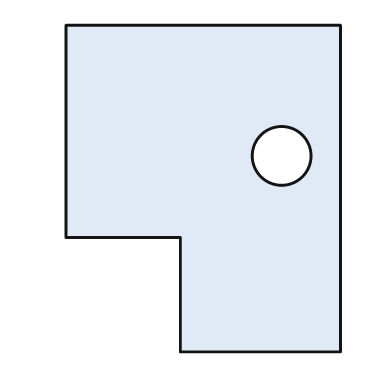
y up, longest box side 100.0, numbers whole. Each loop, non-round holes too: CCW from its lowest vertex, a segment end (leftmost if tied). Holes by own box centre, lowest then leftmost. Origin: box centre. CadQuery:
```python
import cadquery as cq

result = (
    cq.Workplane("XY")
    .moveTo(-7.0, -50.0)
    .lineTo(42.0, -50.0)
    .lineTo(42.0, 50.0)
    .lineTo(-42.0, 50.0)
    .lineTo(-42.0, -15.0)
    .lineTo(-7.0, -15.0)
    .close()
    .moveTo(24.0, 10.0)
    .circle(9.0)
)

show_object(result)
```